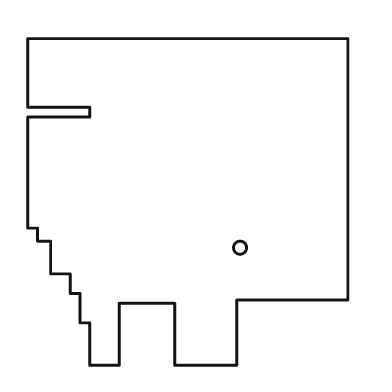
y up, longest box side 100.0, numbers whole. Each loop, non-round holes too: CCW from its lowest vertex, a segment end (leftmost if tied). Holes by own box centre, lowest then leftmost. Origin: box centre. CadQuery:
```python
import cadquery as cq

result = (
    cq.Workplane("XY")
    .moveTo(-30.0, -50.0)
    .lineTo(-21.0, -50.0)
    .lineTo(-21.0, -31.0)
    .lineTo(-4.0, -31.0)
    .lineTo(-4.0, -50.0)
    .lineTo(15.0, -50.0)
    .lineTo(15.0, -30.0)
    .lineTo(49.0, -30.0)
    .lineTo(49.0, 50.0)
    .lineTo(-49.0, 50.0)
    .lineTo(-49.0, 29.0)
    .lineTo(-30.0, 29.0)
    .lineTo(-30.0, 26.0)
    .lineTo(-49.0, 26.0)
    .lineTo(-49.0, -8.0)
    .lineTo(-46.0, -8.0)
    .lineTo(-46.0, -12.0)
    .lineTo(-42.0, -12.0)
    .lineTo(-42.0, -22.0)
    .lineTo(-36.0, -22.0)
    .lineTo(-36.0, -28.0)
    .lineTo(-33.0, -28.0)
    .lineTo(-33.0, -37.0)
    .lineTo(-30.0, -37.0)
    .close()
    .moveTo(16.0, -14.0)
    .circle(2.0)
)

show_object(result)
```